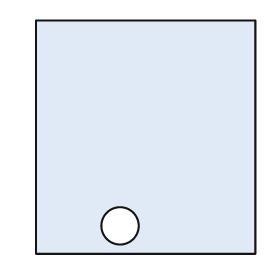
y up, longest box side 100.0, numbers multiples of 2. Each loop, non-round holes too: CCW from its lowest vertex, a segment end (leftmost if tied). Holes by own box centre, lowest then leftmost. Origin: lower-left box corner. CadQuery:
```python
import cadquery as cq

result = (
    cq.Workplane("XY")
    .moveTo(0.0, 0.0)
    .lineTo(94.0, 0.0)
    .lineTo(94.0, 100.0)
    .lineTo(0.0, 100.0)
    .close()
    .moveTo(36.0, 12.0)
    .circle(8.0)
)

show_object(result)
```